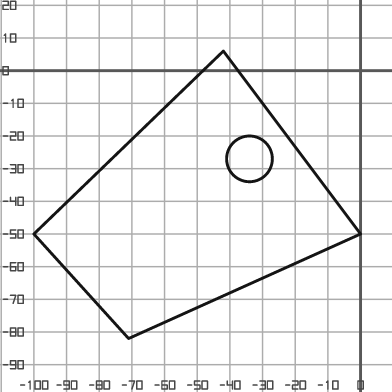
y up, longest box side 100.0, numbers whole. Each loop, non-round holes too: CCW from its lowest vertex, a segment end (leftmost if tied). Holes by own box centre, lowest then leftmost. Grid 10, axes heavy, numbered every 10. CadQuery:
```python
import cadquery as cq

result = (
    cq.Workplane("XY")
    .moveTo(-71.0, -82.0)
    .lineTo(0.0, -50.0)
    .lineTo(-42.0, 6.0)
    .lineTo(-100.0, -50.0)
    .close()
    .moveTo(-34.0, -27.0)
    .circle(7.0)
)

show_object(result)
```